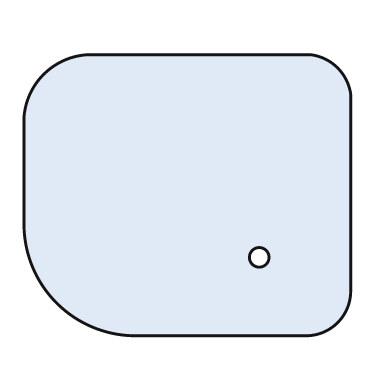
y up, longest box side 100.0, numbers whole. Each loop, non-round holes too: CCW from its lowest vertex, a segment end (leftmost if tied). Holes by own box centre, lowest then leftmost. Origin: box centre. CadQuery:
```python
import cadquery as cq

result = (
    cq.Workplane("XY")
    .moveTo(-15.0, -43.0)
    .lineTo(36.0, -43.0)
    .threePointArc((46.0, -39.0), (50.0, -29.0))
    .lineTo(50.0, 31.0)
    .threePointArc((46.0, 39.0), (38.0, 43.0))
    .lineTo(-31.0, 43.0)
    .threePointArc((-44.0, 37.0), (-50.0, 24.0))
    .lineTo(-50.0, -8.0)
    .threePointArc((-40.0, -33.0), (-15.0, -43.0))
    .close()
    .moveTo(22.0, -19.0)
    .circle(3.0)
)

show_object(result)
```